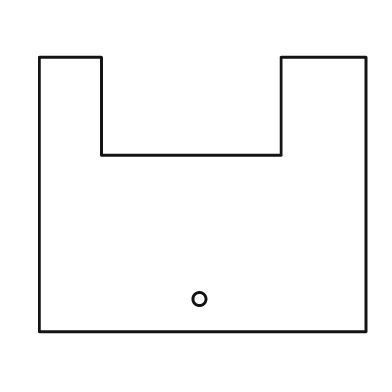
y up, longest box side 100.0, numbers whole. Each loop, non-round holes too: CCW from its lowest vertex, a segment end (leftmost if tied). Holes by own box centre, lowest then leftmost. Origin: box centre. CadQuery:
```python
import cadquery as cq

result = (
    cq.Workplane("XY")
    .moveTo(-50.0, -42.0)
    .lineTo(50.0, -42.0)
    .lineTo(50.0, 42.0)
    .lineTo(24.0, 42.0)
    .lineTo(24.0, 12.0)
    .lineTo(-31.0, 12.0)
    .lineTo(-31.0, 42.0)
    .lineTo(-50.0, 42.0)
    .close()
    .moveTo(-1.0, -32.0)
    .circle(2.0)
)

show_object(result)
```